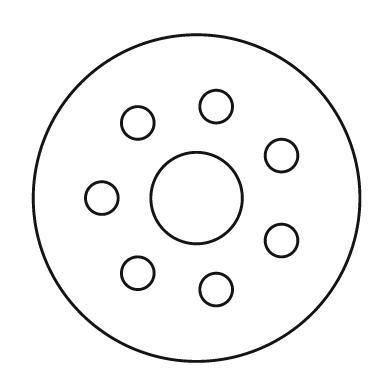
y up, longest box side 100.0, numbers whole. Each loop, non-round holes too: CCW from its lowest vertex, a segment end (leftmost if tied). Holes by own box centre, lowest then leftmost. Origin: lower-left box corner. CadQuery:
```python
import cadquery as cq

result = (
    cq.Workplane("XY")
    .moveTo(50.0, 50.0)
    .circle(50.0)
    .moveTo(56.0, 22.0)
    .circle(5.0)
    .moveTo(32.0, 27.0)
    .circle(5.0)
    .moveTo(76.0, 37.0)
    .circle(5.0)
    .moveTo(21.0, 50.0)
    .circle(5.0)
    .moveTo(50.0, 50.0)
    .circle(14.0)
    .moveTo(76.0, 63.0)
    .circle(5.0)
    .moveTo(32.0, 73.0)
    .circle(5.0)
    .moveTo(56.0, 78.0)
    .circle(5.0)
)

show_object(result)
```